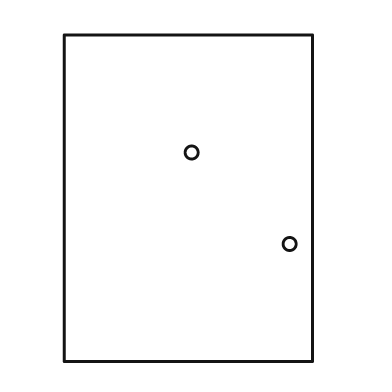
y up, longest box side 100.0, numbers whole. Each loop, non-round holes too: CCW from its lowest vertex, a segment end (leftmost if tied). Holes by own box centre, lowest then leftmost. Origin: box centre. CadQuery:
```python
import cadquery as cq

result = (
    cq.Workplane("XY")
    .moveTo(-38.0, -50.0)
    .lineTo(38.0, -50.0)
    .lineTo(38.0, 50.0)
    .lineTo(-38.0, 50.0)
    .close()
    .moveTo(31.0, -14.0)
    .circle(2.0)
    .moveTo(1.0, 14.0)
    .circle(2.0)
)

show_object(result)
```